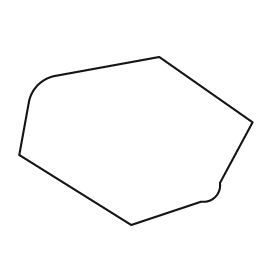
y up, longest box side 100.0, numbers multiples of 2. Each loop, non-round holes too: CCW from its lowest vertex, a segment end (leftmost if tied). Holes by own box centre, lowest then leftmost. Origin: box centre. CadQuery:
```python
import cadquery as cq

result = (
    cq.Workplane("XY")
    .moveTo(-2.0, -36.0)
    .lineTo(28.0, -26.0)
    .threePointArc((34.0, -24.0), (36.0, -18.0))
    .lineTo(50.0, 8.0)
    .lineTo(10.0, 36.0)
    .lineTo(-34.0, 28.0)
    .threePointArc((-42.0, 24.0), (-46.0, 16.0))
    .lineTo(-50.0, -6.0)
    .close()
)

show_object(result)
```